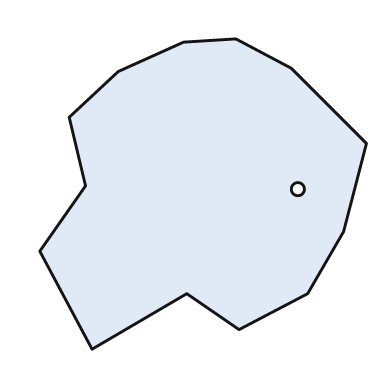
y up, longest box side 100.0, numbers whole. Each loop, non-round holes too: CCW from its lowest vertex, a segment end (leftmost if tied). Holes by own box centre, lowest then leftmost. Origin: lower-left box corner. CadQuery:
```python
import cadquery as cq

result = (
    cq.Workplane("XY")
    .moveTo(16.0, 0.0)
    .lineTo(45.0, 17.0)
    .lineTo(61.0, 6.0)
    .lineTo(82.0, 17.0)
    .lineTo(93.0, 36.0)
    .lineTo(100.0, 63.0)
    .lineTo(77.0, 86.0)
    .lineTo(60.0, 95.0)
    .lineTo(44.0, 94.0)
    .lineTo(24.0, 85.0)
    .lineTo(9.0, 71.0)
    .lineTo(14.0, 50.0)
    .lineTo(0.0, 30.0)
    .close()
    .moveTo(79.0, 49.0)
    .circle(2.0)
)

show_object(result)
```